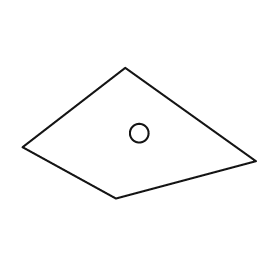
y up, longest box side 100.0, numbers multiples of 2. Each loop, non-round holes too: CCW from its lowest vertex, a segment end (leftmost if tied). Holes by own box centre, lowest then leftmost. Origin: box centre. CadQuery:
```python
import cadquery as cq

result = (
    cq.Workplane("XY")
    .moveTo(-10.0, -28.0)
    .lineTo(50.0, -12.0)
    .lineTo(-6.0, 28.0)
    .lineTo(-50.0, -6.0)
    .close()
    .moveTo(0.0, 0.0)
    .circle(4.0)
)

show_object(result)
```